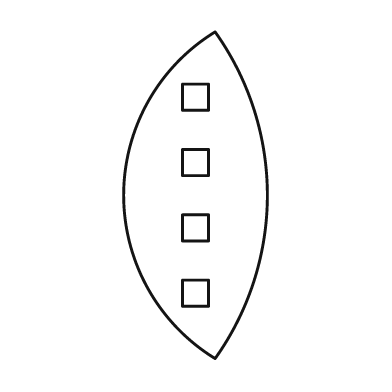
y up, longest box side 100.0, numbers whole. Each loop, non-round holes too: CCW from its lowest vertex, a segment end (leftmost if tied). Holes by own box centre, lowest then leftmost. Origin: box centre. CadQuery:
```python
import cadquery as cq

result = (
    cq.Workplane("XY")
    .moveTo(6.0, -50.0)
    .threePointArc((22.0, 0.0), (6.0, 50.0))
    .threePointArc((-22.0, 0.0), (6.0, -50.0))
    .close()
    .moveTo(-4.0, -34.0)
    .lineTo(4.0, -34.0)
    .lineTo(4.0, -26.0)
    .lineTo(-4.0, -26.0)
    .close()
    .moveTo(-4.0, -14.0)
    .lineTo(4.0, -14.0)
    .lineTo(4.0, -6.0)
    .lineTo(-4.0, -6.0)
    .close()
    .moveTo(-4.0, 6.0)
    .lineTo(4.0, 6.0)
    .lineTo(4.0, 14.0)
    .lineTo(-4.0, 14.0)
    .close()
    .moveTo(-4.0, 26.0)
    .lineTo(4.0, 26.0)
    .lineTo(4.0, 34.0)
    .lineTo(-4.0, 34.0)
    .close()
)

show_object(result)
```